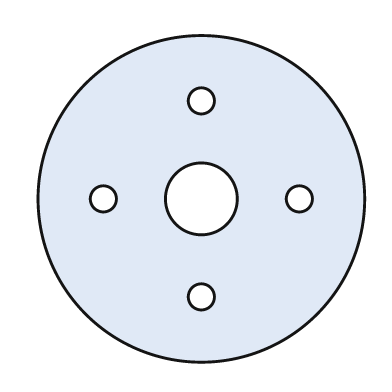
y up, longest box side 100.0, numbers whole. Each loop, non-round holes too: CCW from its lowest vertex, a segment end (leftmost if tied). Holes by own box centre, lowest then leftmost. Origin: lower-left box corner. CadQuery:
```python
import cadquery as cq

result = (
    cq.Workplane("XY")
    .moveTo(50.0, 50.0)
    .circle(50.0)
    .moveTo(50.0, 20.0)
    .circle(4.0)
    .moveTo(20.0, 50.0)
    .circle(4.0)
    .moveTo(50.0, 50.0)
    .circle(11.0)
    .moveTo(80.0, 50.0)
    .circle(4.0)
    .moveTo(50.0, 80.0)
    .circle(4.0)
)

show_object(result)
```